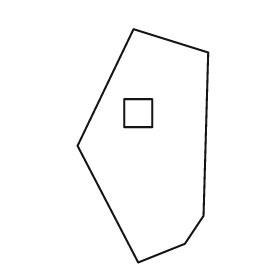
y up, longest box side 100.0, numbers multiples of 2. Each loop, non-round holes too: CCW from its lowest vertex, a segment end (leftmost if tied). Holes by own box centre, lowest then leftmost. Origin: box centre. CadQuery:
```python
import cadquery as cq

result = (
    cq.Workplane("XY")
    .moveTo(-2.0, -50.0)
    .lineTo(18.0, -42.0)
    .lineTo(26.0, -30.0)
    .lineTo(28.0, 40.0)
    .lineTo(-4.0, 50.0)
    .lineTo(-28.0, 0.0)
    .close()
    .moveTo(-8.0, 8.0)
    .lineTo(4.0, 8.0)
    .lineTo(4.0, 20.0)
    .lineTo(-8.0, 20.0)
    .close()
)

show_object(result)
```